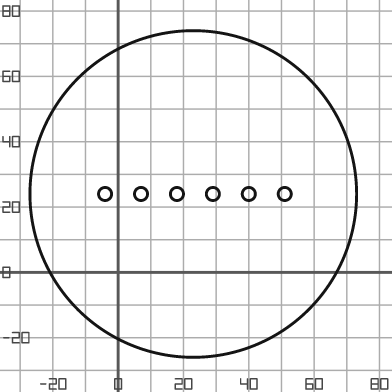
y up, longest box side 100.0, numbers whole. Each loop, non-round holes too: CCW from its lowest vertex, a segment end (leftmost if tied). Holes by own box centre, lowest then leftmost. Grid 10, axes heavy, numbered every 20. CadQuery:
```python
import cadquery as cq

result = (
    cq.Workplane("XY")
    .moveTo(23.0, 24.0)
    .circle(50.0)
    .moveTo(-4.0, 24.0)
    .circle(2.0)
    .moveTo(7.0, 24.0)
    .circle(2.0)
    .moveTo(18.0, 24.0)
    .circle(2.0)
    .moveTo(29.0, 24.0)
    .circle(2.0)
    .moveTo(40.0, 24.0)
    .circle(2.0)
    .moveTo(51.0, 24.0)
    .circle(2.0)
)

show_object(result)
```